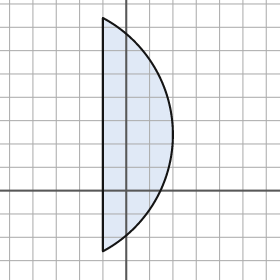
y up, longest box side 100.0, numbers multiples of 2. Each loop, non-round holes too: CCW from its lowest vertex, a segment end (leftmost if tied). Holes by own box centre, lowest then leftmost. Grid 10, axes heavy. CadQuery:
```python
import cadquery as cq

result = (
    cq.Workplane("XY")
    .moveTo(-10.0, -26.0)
    .threePointArc((20.0, 24.0), (-10.0, 74.0))
    .close()
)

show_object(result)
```